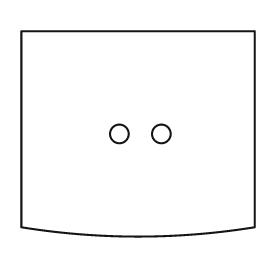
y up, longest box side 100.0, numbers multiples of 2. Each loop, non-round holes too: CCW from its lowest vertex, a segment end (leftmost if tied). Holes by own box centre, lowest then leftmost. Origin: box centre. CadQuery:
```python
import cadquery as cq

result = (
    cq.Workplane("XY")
    .moveTo(-50.0, -40.0)
    .threePointArc((0.0, -44.0), (50.0, -40.0))
    .lineTo(50.0, 44.0)
    .lineTo(-50.0, 44.0)
    .close()
    .moveTo(-8.0, 0.0)
    .circle(4.0)
    .moveTo(10.0, 0.0)
    .circle(4.0)
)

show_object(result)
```